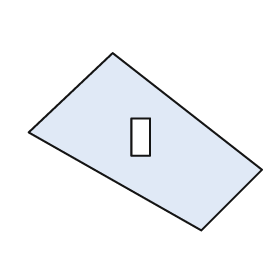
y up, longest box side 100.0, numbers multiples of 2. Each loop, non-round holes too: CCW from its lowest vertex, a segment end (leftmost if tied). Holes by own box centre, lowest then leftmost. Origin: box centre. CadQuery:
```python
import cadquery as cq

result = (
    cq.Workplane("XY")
    .moveTo(24.0, -38.0)
    .lineTo(50.0, -12.0)
    .lineTo(-14.0, 38.0)
    .lineTo(-50.0, 4.0)
    .close()
    .moveTo(-6.0, -6.0)
    .lineTo(2.0, -6.0)
    .lineTo(2.0, 10.0)
    .lineTo(-6.0, 10.0)
    .close()
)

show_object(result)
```